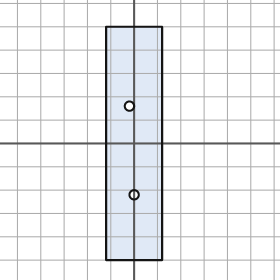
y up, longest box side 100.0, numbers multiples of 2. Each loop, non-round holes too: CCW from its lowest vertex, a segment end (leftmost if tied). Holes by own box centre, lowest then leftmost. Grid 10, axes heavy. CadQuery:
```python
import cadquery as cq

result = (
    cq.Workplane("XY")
    .moveTo(-12.0, -50.0)
    .lineTo(12.0, -50.0)
    .lineTo(12.0, 50.0)
    .lineTo(-12.0, 50.0)
    .close()
    .moveTo(0.0, -22.0)
    .circle(2.0)
    .moveTo(-2.0, 16.0)
    .circle(2.0)
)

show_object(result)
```